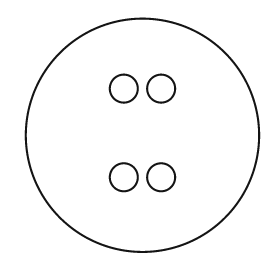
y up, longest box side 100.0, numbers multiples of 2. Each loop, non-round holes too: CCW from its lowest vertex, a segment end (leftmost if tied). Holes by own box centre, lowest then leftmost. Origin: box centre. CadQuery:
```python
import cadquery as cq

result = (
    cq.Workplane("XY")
    .moveTo(0.0, 0.0)
    .circle(50.0)
    .moveTo(-8.0, -18.0)
    .circle(6.0)
    .moveTo(8.0, -18.0)
    .circle(6.0)
    .moveTo(-8.0, 20.0)
    .circle(6.0)
    .moveTo(8.0, 20.0)
    .circle(6.0)
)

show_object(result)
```